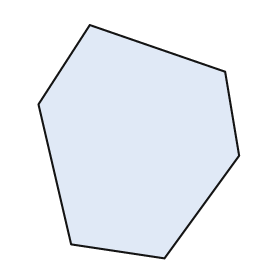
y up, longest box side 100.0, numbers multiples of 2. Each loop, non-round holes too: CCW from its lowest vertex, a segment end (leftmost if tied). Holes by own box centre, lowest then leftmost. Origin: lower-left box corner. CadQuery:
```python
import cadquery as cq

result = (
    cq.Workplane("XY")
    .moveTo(54.0, 0.0)
    .lineTo(86.0, 44.0)
    .lineTo(80.0, 80.0)
    .lineTo(22.0, 100.0)
    .lineTo(0.0, 66.0)
    .lineTo(14.0, 6.0)
    .close()
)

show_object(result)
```